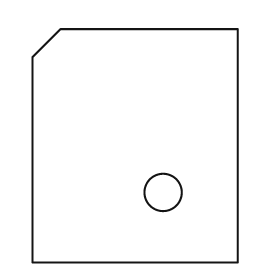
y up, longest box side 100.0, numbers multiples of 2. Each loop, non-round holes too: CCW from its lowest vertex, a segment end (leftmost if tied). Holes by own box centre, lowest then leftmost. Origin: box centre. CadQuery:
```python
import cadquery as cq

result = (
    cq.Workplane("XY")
    .moveTo(-44.0, -50.0)
    .lineTo(44.0, -50.0)
    .lineTo(44.0, 50.0)
    .lineTo(-32.0, 50.0)
    .lineTo(-44.0, 38.0)
    .close()
    .moveTo(12.0, -20.0)
    .circle(8.0)
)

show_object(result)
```